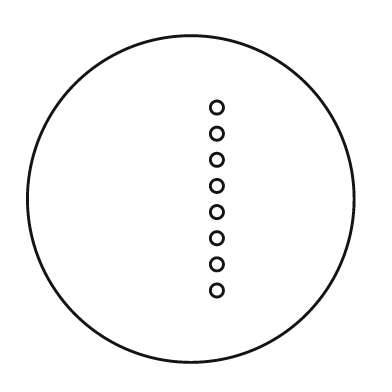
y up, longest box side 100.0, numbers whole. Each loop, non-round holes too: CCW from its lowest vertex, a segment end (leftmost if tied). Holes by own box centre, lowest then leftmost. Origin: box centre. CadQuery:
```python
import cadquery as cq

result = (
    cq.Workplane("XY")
    .moveTo(0.0, 0.0)
    .circle(50.0)
    .moveTo(8.0, -28.0)
    .circle(2.0)
    .moveTo(8.0, -20.0)
    .circle(2.0)
    .moveTo(8.0, -12.0)
    .circle(2.0)
    .moveTo(8.0, -4.0)
    .circle(2.0)
    .moveTo(8.0, 4.0)
    .circle(2.0)
    .moveTo(8.0, 12.0)
    .circle(2.0)
    .moveTo(8.0, 20.0)
    .circle(2.0)
    .moveTo(8.0, 28.0)
    .circle(2.0)
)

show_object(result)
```